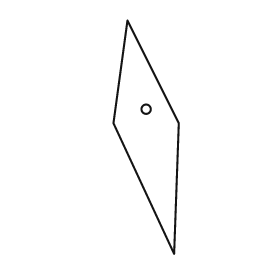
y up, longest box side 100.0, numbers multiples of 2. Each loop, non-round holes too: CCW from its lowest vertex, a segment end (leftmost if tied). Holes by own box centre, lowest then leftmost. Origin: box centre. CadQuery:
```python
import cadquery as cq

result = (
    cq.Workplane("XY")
    .moveTo(12.0, -50.0)
    .lineTo(14.0, 6.0)
    .lineTo(-8.0, 50.0)
    .lineTo(-14.0, 6.0)
    .close()
    .moveTo(0.0, 12.0)
    .circle(2.0)
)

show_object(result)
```